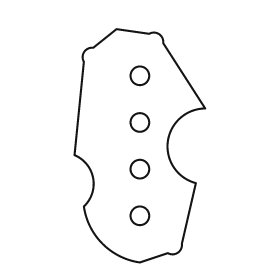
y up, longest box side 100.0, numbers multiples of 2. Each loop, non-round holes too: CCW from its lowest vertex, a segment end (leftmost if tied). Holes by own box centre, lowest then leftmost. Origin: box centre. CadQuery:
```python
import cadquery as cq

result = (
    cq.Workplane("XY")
    .moveTo(0.0, -50.0)
    .lineTo(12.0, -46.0)
    .threePointArc((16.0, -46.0), (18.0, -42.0))
    .lineTo(24.0, -16.0)
    .threePointArc((12.0, 2.0), (28.0, 16.0))
    .lineTo(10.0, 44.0)
    .threePointArc((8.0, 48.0), (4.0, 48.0))
    .lineTo(-10.0, 50.0)
    .lineTo(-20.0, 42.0)
    .threePointArc((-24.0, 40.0), (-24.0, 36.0))
    .lineTo(-28.0, -4.0)
    .threePointArc((-20.0, -14.0), (-24.0, -26.0))
    .threePointArc((-16.0, -42.0), (0.0, -50.0))
    .close()
    .moveTo(0.0, -30.0)
    .circle(4.0)
    .moveTo(0.0, -10.0)
    .circle(4.0)
    .moveTo(0.0, 10.0)
    .circle(4.0)
    .moveTo(0.0, 30.0)
    .circle(4.0)
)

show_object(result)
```